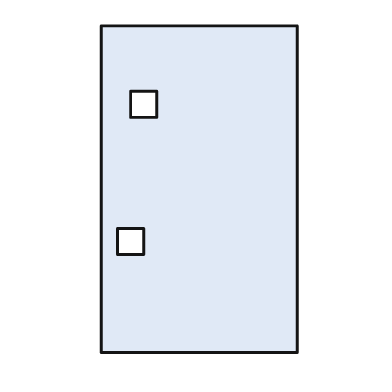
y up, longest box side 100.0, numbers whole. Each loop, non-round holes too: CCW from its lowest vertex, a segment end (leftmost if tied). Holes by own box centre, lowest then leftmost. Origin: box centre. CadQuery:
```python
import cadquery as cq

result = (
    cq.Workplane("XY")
    .moveTo(-30.0, -50.0)
    .lineTo(30.0, -50.0)
    .lineTo(30.0, 50.0)
    .lineTo(-30.0, 50.0)
    .close()
    .moveTo(-25.0, -20.0)
    .lineTo(-17.0, -20.0)
    .lineTo(-17.0, -12.0)
    .lineTo(-25.0, -12.0)
    .close()
    .moveTo(-21.0, 22.0)
    .lineTo(-13.0, 22.0)
    .lineTo(-13.0, 30.0)
    .lineTo(-21.0, 30.0)
    .close()
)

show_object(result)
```